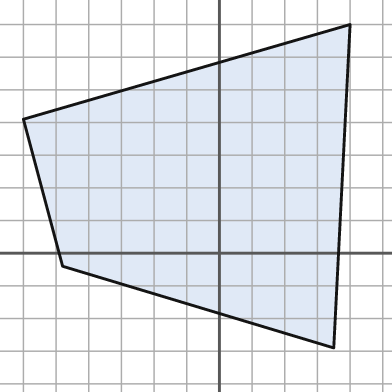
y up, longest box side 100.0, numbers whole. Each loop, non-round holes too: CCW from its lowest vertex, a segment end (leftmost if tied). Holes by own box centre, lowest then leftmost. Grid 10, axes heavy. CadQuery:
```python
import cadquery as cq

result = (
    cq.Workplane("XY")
    .moveTo(35.0, -29.0)
    .lineTo(40.0, 70.0)
    .lineTo(-60.0, 41.0)
    .lineTo(-48.0, -4.0)
    .close()
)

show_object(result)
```